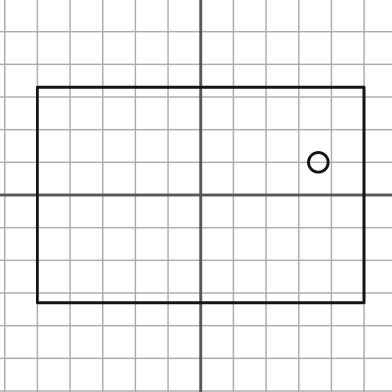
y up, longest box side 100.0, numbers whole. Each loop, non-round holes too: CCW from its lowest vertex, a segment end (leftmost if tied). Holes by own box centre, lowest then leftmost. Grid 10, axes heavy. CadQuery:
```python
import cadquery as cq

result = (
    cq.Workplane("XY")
    .moveTo(-50.0, -33.0)
    .lineTo(50.0, -33.0)
    .lineTo(50.0, 33.0)
    .lineTo(-50.0, 33.0)
    .close()
    .moveTo(36.0, 10.0)
    .circle(3.0)
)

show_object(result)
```